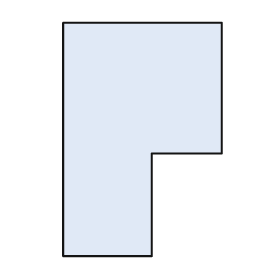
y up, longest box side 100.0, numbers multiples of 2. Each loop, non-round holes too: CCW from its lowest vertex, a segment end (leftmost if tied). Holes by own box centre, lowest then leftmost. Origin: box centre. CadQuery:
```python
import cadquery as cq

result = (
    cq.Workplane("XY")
    .moveTo(-34.0, -50.0)
    .lineTo(4.0, -50.0)
    .lineTo(4.0, -6.0)
    .lineTo(34.0, -6.0)
    .lineTo(34.0, 50.0)
    .lineTo(-34.0, 50.0)
    .close()
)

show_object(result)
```